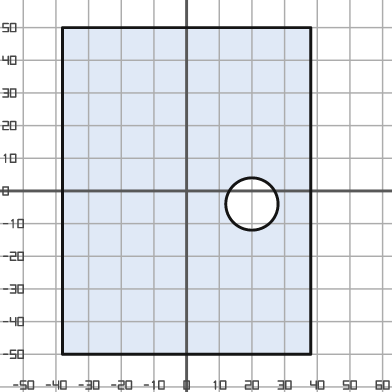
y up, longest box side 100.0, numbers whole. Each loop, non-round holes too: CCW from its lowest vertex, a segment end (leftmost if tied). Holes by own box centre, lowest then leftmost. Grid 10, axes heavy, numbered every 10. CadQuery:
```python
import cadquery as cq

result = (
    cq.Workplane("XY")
    .moveTo(-38.0, -50.0)
    .lineTo(38.0, -50.0)
    .lineTo(38.0, 50.0)
    .lineTo(-38.0, 50.0)
    .close()
    .moveTo(20.0, -4.0)
    .circle(8.0)
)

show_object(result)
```